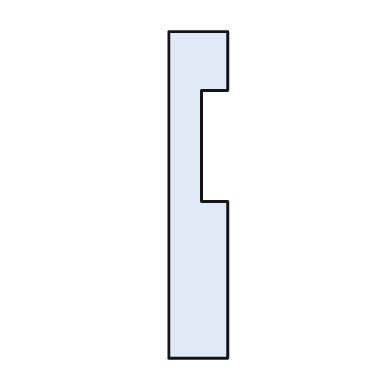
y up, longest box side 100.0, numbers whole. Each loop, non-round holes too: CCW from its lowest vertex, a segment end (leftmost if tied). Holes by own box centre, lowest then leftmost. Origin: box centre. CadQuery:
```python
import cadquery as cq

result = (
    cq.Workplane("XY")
    .moveTo(-9.0, -50.0)
    .lineTo(9.0, -50.0)
    .lineTo(9.0, -2.0)
    .lineTo(1.0, -2.0)
    .lineTo(1.0, 32.0)
    .lineTo(9.0, 32.0)
    .lineTo(9.0, 50.0)
    .lineTo(-9.0, 50.0)
    .close()
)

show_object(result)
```